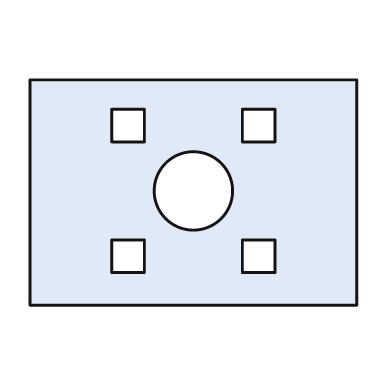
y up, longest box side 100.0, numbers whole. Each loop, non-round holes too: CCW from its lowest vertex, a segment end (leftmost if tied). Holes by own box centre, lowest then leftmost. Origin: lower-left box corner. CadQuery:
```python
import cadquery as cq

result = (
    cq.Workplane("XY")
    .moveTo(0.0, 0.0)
    .lineTo(100.0, 0.0)
    .lineTo(100.0, 69.0)
    .lineTo(0.0, 69.0)
    .close()
    .moveTo(25.0, 10.0)
    .lineTo(35.0, 10.0)
    .lineTo(35.0, 20.0)
    .lineTo(25.0, 20.0)
    .close()
    .moveTo(65.0, 10.0)
    .lineTo(75.0, 10.0)
    .lineTo(75.0, 20.0)
    .lineTo(65.0, 20.0)
    .close()
    .moveTo(50.0, 35.0)
    .circle(12.0)
    .moveTo(25.0, 50.0)
    .lineTo(35.0, 50.0)
    .lineTo(35.0, 60.0)
    .lineTo(25.0, 60.0)
    .close()
    .moveTo(65.0, 50.0)
    .lineTo(75.0, 50.0)
    .lineTo(75.0, 60.0)
    .lineTo(65.0, 60.0)
    .close()
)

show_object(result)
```